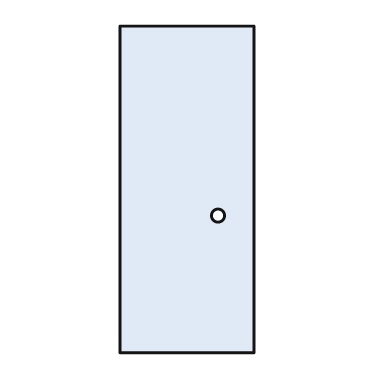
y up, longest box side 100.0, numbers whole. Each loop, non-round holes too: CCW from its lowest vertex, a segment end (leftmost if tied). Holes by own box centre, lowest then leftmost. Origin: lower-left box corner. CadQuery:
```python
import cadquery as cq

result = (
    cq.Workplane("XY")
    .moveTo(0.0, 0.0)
    .lineTo(41.0, 0.0)
    .lineTo(41.0, 100.0)
    .lineTo(0.0, 100.0)
    .close()
    .moveTo(30.0, 42.0)
    .circle(2.0)
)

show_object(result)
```